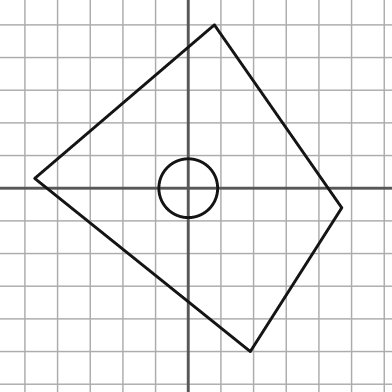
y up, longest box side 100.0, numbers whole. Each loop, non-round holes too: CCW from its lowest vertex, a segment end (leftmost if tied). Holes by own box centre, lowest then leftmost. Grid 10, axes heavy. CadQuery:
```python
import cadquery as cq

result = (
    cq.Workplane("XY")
    .moveTo(19.0, -50.0)
    .lineTo(47.0, -6.0)
    .lineTo(8.0, 50.0)
    .lineTo(-47.0, 3.0)
    .close()
    .moveTo(0.0, 0.0)
    .circle(9.0)
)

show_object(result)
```